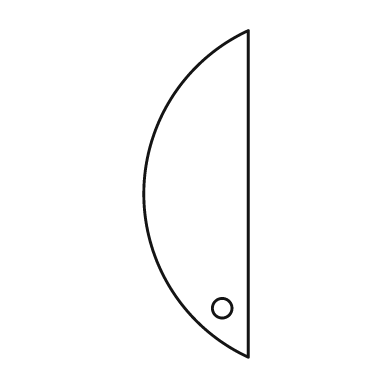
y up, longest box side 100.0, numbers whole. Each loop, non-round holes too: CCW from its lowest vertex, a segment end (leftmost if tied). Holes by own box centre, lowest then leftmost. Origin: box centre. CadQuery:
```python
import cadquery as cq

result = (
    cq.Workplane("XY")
    .moveTo(16.0, -50.0)
    .lineTo(16.0, 50.0)
    .threePointArc((-16.0, 0.0), (16.0, -50.0))
    .close()
    .moveTo(8.0, -35.0)
    .circle(3.0)
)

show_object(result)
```